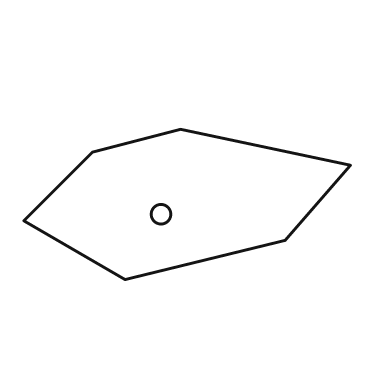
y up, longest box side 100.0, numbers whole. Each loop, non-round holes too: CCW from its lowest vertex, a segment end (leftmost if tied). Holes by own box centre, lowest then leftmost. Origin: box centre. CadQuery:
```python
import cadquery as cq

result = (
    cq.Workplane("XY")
    .moveTo(-19.0, -23.0)
    .lineTo(30.0, -11.0)
    .lineTo(50.0, 12.0)
    .lineTo(-2.0, 23.0)
    .lineTo(-29.0, 16.0)
    .lineTo(-50.0, -5.0)
    .close()
    .moveTo(-8.0, -3.0)
    .circle(3.0)
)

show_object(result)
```